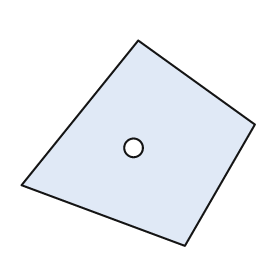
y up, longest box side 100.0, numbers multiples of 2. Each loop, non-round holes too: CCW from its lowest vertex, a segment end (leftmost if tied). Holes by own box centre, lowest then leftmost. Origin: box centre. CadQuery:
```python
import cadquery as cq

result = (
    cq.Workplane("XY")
    .moveTo(20.0, -44.0)
    .lineTo(50.0, 8.0)
    .lineTo(0.0, 44.0)
    .lineTo(-50.0, -18.0)
    .close()
    .moveTo(-2.0, -2.0)
    .circle(4.0)
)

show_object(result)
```